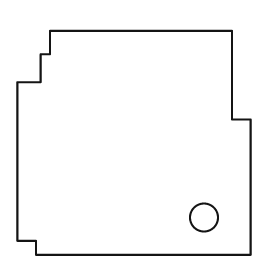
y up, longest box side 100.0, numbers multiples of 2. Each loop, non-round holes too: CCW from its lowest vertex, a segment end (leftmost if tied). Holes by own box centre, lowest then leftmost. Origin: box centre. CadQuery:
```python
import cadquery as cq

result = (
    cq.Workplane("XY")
    .moveTo(-42.0, -48.0)
    .lineTo(50.0, -48.0)
    .lineTo(50.0, 10.0)
    .lineTo(42.0, 10.0)
    .lineTo(42.0, 48.0)
    .lineTo(-36.0, 48.0)
    .lineTo(-36.0, 38.0)
    .lineTo(-40.0, 38.0)
    .lineTo(-40.0, 26.0)
    .lineTo(-50.0, 26.0)
    .lineTo(-50.0, -42.0)
    .lineTo(-42.0, -42.0)
    .close()
    .moveTo(30.0, -32.0)
    .circle(6.0)
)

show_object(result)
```